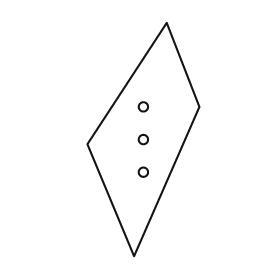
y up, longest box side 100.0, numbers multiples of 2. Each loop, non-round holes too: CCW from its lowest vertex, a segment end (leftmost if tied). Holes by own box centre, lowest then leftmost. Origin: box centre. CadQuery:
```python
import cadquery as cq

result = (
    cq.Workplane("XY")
    .moveTo(-4.0, -50.0)
    .lineTo(24.0, 14.0)
    .lineTo(10.0, 50.0)
    .lineTo(-24.0, -2.0)
    .close()
    .moveTo(0.0, -14.0)
    .circle(2.0)
    .moveTo(0.0, 0.0)
    .circle(2.0)
    .moveTo(0.0, 14.0)
    .circle(2.0)
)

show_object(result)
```